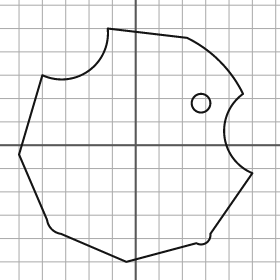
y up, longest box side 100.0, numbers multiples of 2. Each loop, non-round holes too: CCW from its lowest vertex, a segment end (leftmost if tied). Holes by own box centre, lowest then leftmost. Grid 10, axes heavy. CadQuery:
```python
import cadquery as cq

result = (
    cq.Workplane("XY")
    .moveTo(-4.0, -50.0)
    .lineTo(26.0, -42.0)
    .threePointArc((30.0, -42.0), (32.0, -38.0))
    .lineTo(50.0, -12.0)
    .threePointArc((38.0, 4.0), (46.0, 22.0))
    .threePointArc((36.0, 36.0), (22.0, 46.0))
    .lineTo(-12.0, 50.0)
    .threePointArc((-20.0, 32.0), (-40.0, 30.0))
    .lineTo(-50.0, -4.0)
    .lineTo(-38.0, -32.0)
    .threePointArc((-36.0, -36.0), (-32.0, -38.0))
    .close()
    .moveTo(28.0, 18.0)
    .circle(4.0)
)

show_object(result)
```